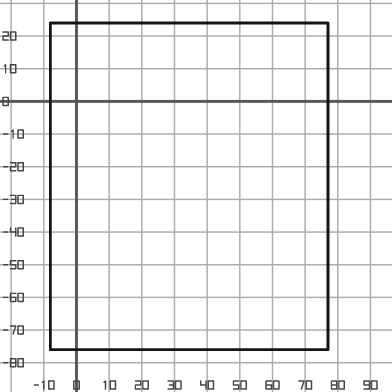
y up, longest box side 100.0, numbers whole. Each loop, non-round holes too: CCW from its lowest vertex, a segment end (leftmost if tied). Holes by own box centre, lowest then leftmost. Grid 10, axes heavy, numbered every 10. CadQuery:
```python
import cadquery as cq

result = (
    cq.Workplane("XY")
    .moveTo(-8.0, -76.0)
    .lineTo(77.0, -76.0)
    .lineTo(77.0, 24.0)
    .lineTo(-8.0, 24.0)
    .close()
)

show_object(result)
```